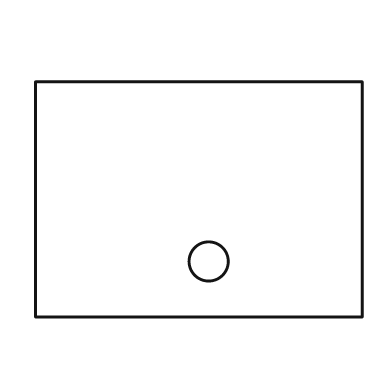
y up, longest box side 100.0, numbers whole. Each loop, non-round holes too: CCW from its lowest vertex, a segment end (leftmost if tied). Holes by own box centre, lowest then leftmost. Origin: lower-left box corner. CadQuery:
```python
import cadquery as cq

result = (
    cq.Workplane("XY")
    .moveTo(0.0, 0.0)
    .lineTo(100.0, 0.0)
    .lineTo(100.0, 72.0)
    .lineTo(0.0, 72.0)
    .close()
    .moveTo(53.0, 17.0)
    .circle(6.0)
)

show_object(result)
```